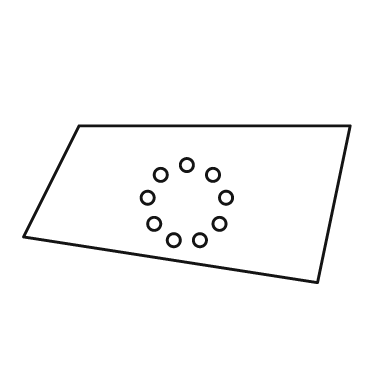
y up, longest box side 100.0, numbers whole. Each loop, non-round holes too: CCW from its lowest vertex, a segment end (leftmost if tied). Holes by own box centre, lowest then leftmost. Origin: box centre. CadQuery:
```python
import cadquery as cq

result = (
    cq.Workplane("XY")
    .moveTo(40.0, -24.0)
    .lineTo(50.0, 24.0)
    .lineTo(-33.0, 24.0)
    .lineTo(-50.0, -10.0)
    .close()
    .moveTo(-4.0, -11.0)
    .circle(2.0)
    .moveTo(4.0, -11.0)
    .circle(2.0)
    .moveTo(-10.0, -6.0)
    .circle(2.0)
    .moveTo(10.0, -6.0)
    .circle(2.0)
    .moveTo(-12.0, 2.0)
    .circle(2.0)
    .moveTo(12.0, 2.0)
    .circle(2.0)
    .moveTo(-8.0, 9.0)
    .circle(2.0)
    .moveTo(8.0, 9.0)
    .circle(2.0)
    .moveTo(0.0, 12.0)
    .circle(2.0)
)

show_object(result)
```